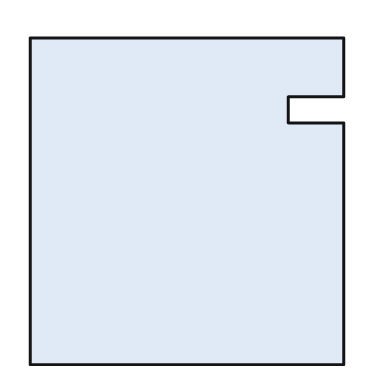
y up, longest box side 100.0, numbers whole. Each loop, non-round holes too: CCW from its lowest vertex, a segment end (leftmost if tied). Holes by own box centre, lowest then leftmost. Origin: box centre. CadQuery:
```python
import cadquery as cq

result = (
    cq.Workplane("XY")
    .moveTo(-48.0, -50.0)
    .lineTo(48.0, -50.0)
    .lineTo(48.0, 24.0)
    .lineTo(31.0, 24.0)
    .lineTo(31.0, 32.0)
    .lineTo(48.0, 32.0)
    .lineTo(48.0, 50.0)
    .lineTo(-48.0, 50.0)
    .close()
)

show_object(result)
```